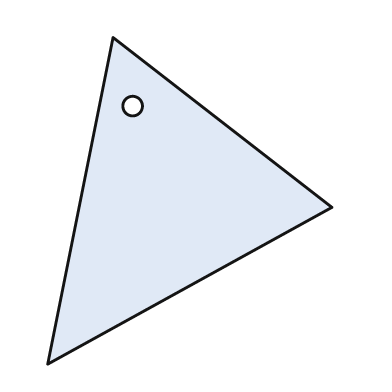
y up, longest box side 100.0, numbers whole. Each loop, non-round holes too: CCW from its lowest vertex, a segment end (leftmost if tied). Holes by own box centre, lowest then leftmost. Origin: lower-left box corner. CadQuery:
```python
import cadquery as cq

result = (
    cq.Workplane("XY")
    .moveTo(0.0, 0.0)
    .lineTo(87.0, 48.0)
    .lineTo(20.0, 100.0)
    .close()
    .moveTo(26.0, 79.0)
    .circle(3.0)
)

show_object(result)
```